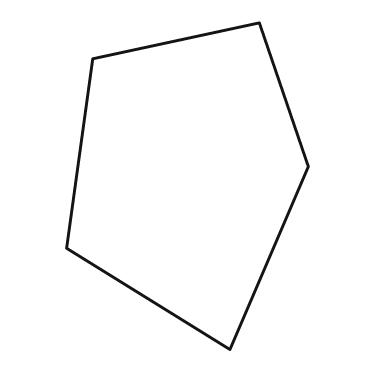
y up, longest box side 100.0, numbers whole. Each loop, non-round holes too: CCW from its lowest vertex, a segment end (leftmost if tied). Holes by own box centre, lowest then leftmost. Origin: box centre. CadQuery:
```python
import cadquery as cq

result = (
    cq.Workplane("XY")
    .moveTo(13.0, -50.0)
    .lineTo(37.0, 6.0)
    .lineTo(22.0, 50.0)
    .lineTo(-29.0, 39.0)
    .lineTo(-37.0, -19.0)
    .close()
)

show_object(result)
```